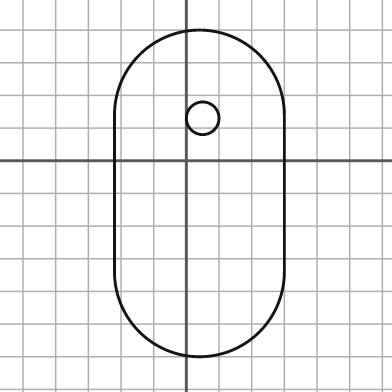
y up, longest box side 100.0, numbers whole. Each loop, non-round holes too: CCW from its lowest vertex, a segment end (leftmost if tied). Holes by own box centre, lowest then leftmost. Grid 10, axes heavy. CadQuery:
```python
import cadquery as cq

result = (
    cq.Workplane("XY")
    .moveTo(-22.0, -34.0)
    .threePointArc((4.0, -60.0), (30.0, -34.0))
    .lineTo(30.0, 14.0)
    .threePointArc((4.0, 40.0), (-22.0, 14.0))
    .close()
    .moveTo(5.0, 13.0)
    .circle(5.0)
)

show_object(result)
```